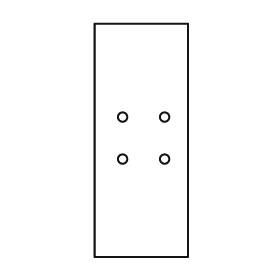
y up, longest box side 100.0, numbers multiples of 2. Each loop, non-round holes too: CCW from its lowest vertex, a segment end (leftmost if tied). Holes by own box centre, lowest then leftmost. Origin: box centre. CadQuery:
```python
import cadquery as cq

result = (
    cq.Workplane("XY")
    .moveTo(-20.0, -50.0)
    .lineTo(20.0, -50.0)
    .lineTo(20.0, 50.0)
    .lineTo(-20.0, 50.0)
    .close()
    .moveTo(-8.0, -8.0)
    .circle(2.0)
    .moveTo(10.0, -8.0)
    .circle(2.0)
    .moveTo(-8.0, 10.0)
    .circle(2.0)
    .moveTo(10.0, 10.0)
    .circle(2.0)
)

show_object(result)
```